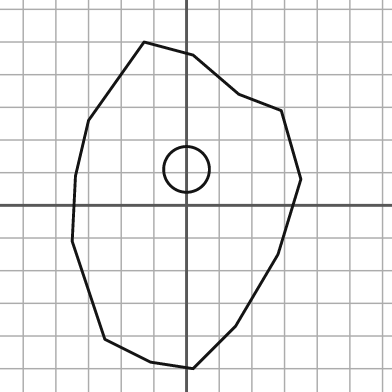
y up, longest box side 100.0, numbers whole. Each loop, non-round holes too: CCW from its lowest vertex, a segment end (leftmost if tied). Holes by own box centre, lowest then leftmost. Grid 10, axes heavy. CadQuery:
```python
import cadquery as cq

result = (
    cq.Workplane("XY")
    .moveTo(2.0, -50.0)
    .lineTo(15.0, -37.0)
    .lineTo(28.0, -15.0)
    .lineTo(35.0, 8.0)
    .lineTo(29.0, 29.0)
    .lineTo(16.0, 34.0)
    .lineTo(2.0, 46.0)
    .lineTo(-13.0, 50.0)
    .lineTo(-30.0, 26.0)
    .lineTo(-34.0, 9.0)
    .lineTo(-35.0, -11.0)
    .lineTo(-25.0, -41.0)
    .lineTo(-11.0, -48.0)
    .close()
    .moveTo(0.0, 11.0)
    .circle(7.0)
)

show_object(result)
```